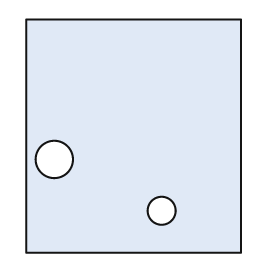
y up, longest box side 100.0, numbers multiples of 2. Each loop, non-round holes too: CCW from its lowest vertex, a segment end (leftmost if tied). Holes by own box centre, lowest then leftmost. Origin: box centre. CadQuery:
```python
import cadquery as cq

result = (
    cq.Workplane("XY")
    .moveTo(-46.0, -50.0)
    .lineTo(46.0, -50.0)
    .lineTo(46.0, 50.0)
    .lineTo(-46.0, 50.0)
    .close()
    .moveTo(12.0, -32.0)
    .circle(6.0)
    .moveTo(-34.0, -10.0)
    .circle(8.0)
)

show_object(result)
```